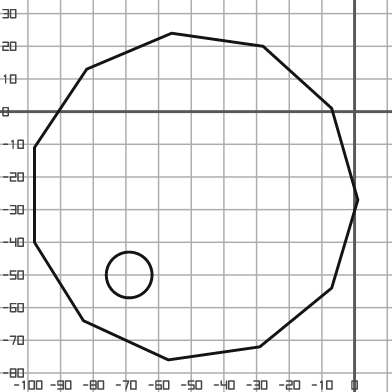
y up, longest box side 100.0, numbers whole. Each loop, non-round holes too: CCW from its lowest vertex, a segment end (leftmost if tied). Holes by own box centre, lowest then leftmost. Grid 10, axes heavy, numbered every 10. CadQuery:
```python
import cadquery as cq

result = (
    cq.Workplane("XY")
    .moveTo(-57.0, -76.0)
    .lineTo(-29.0, -72.0)
    .lineTo(-7.0, -54.0)
    .lineTo(1.0, -27.0)
    .lineTo(-7.0, 1.0)
    .lineTo(-28.0, 20.0)
    .lineTo(-56.0, 24.0)
    .lineTo(-82.0, 13.0)
    .lineTo(-98.0, -11.0)
    .lineTo(-98.0, -40.0)
    .lineTo(-83.0, -64.0)
    .close()
    .moveTo(-69.0, -50.0)
    .circle(7.0)
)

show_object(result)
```